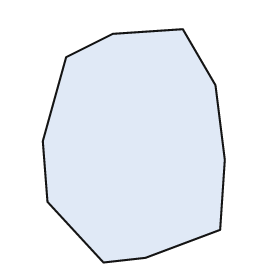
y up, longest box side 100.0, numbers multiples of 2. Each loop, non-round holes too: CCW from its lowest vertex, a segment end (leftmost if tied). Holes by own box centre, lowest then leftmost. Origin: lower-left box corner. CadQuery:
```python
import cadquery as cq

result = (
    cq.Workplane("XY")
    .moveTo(26.0, 0.0)
    .lineTo(44.0, 2.0)
    .lineTo(76.0, 14.0)
    .lineTo(78.0, 44.0)
    .lineTo(74.0, 76.0)
    .lineTo(60.0, 100.0)
    .lineTo(30.0, 98.0)
    .lineTo(10.0, 88.0)
    .lineTo(0.0, 52.0)
    .lineTo(2.0, 26.0)
    .close()
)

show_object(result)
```